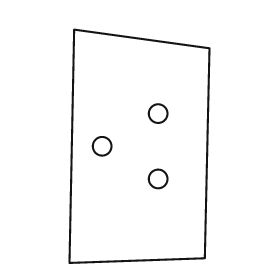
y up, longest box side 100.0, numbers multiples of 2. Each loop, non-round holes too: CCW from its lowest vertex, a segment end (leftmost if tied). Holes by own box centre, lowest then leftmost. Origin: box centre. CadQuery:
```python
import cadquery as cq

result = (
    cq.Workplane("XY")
    .moveTo(-30.0, -50.0)
    .lineTo(28.0, -48.0)
    .lineTo(30.0, 42.0)
    .lineTo(-28.0, 50.0)
    .close()
    .moveTo(8.0, -14.0)
    .circle(4.0)
    .moveTo(-16.0, 0.0)
    .circle(4.0)
    .moveTo(8.0, 14.0)
    .circle(4.0)
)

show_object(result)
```